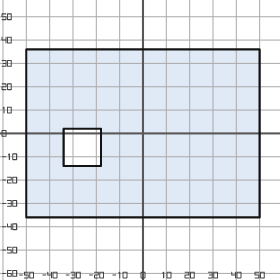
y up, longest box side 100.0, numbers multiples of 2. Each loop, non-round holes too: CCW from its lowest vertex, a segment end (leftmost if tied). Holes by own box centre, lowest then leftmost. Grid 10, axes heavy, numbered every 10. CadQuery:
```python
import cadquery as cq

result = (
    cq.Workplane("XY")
    .moveTo(-50.0, -36.0)
    .lineTo(50.0, -36.0)
    .lineTo(50.0, 36.0)
    .lineTo(-50.0, 36.0)
    .close()
    .moveTo(-34.0, -14.0)
    .lineTo(-18.0, -14.0)
    .lineTo(-18.0, 2.0)
    .lineTo(-34.0, 2.0)
    .close()
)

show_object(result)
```